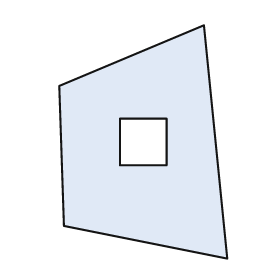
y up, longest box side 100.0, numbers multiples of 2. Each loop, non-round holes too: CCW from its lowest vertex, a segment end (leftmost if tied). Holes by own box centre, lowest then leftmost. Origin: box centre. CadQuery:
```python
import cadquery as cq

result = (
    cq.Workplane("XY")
    .moveTo(36.0, -50.0)
    .lineTo(26.0, 50.0)
    .lineTo(-36.0, 24.0)
    .lineTo(-34.0, -36.0)
    .close()
    .moveTo(-10.0, -10.0)
    .lineTo(10.0, -10.0)
    .lineTo(10.0, 10.0)
    .lineTo(-10.0, 10.0)
    .close()
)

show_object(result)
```